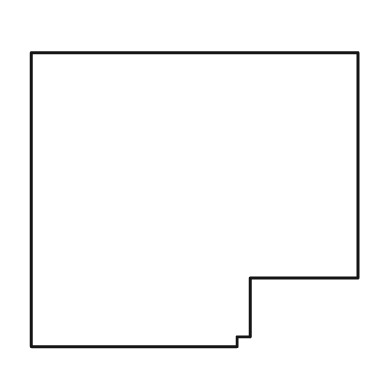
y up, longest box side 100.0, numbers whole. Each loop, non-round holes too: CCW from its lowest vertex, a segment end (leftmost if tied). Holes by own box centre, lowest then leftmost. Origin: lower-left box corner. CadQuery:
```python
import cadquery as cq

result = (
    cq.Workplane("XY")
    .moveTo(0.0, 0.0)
    .lineTo(63.0, 0.0)
    .lineTo(63.0, 3.0)
    .lineTo(67.0, 3.0)
    .lineTo(67.0, 21.0)
    .lineTo(100.0, 21.0)
    .lineTo(100.0, 90.0)
    .lineTo(0.0, 90.0)
    .close()
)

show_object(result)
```